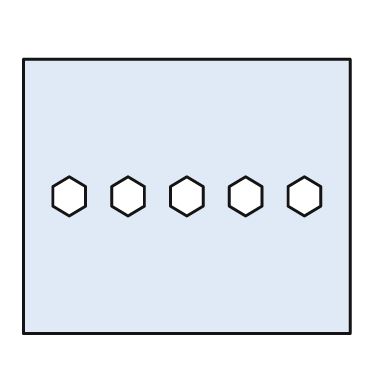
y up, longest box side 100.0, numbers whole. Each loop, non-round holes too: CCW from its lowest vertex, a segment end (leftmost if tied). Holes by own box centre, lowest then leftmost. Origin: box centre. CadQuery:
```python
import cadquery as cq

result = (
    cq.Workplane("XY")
    .moveTo(-50.0, -42.0)
    .lineTo(50.0, -42.0)
    .lineTo(50.0, 42.0)
    .lineTo(-50.0, 42.0)
    .close()
    .moveTo(-36.0, -6.0)
    .lineTo(-31.0, -3.0)
    .lineTo(-31.0, 3.0)
    .lineTo(-36.0, 6.0)
    .lineTo(-41.0, 3.0)
    .lineTo(-41.0, -3.0)
    .close()
    .moveTo(-18.0, -6.0)
    .lineTo(-13.0, -3.0)
    .lineTo(-13.0, 3.0)
    .lineTo(-18.0, 6.0)
    .lineTo(-23.0, 3.0)
    .lineTo(-23.0, -3.0)
    .close()
    .moveTo(0.0, -6.0)
    .lineTo(5.0, -3.0)
    .lineTo(5.0, 3.0)
    .lineTo(0.0, 6.0)
    .lineTo(-5.0, 3.0)
    .lineTo(-5.0, -3.0)
    .close()
    .moveTo(18.0, -6.0)
    .lineTo(23.0, -3.0)
    .lineTo(23.0, 3.0)
    .lineTo(18.0, 6.0)
    .lineTo(13.0, 3.0)
    .lineTo(13.0, -3.0)
    .close()
    .moveTo(36.0, -6.0)
    .lineTo(41.0, -3.0)
    .lineTo(41.0, 3.0)
    .lineTo(36.0, 6.0)
    .lineTo(31.0, 3.0)
    .lineTo(31.0, -3.0)
    .close()
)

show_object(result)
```